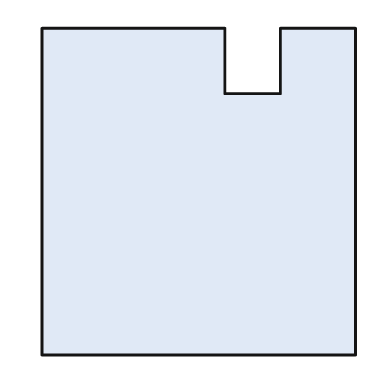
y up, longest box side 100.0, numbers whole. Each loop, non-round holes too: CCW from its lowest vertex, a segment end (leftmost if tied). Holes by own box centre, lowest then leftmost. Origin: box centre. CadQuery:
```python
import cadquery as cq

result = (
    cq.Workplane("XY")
    .moveTo(-48.0, -50.0)
    .lineTo(48.0, -50.0)
    .lineTo(48.0, 50.0)
    .lineTo(25.0, 50.0)
    .lineTo(25.0, 30.0)
    .lineTo(8.0, 30.0)
    .lineTo(8.0, 50.0)
    .lineTo(-48.0, 50.0)
    .close()
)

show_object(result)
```